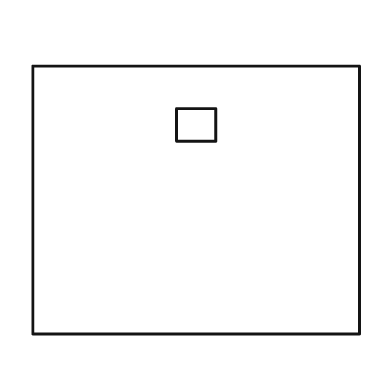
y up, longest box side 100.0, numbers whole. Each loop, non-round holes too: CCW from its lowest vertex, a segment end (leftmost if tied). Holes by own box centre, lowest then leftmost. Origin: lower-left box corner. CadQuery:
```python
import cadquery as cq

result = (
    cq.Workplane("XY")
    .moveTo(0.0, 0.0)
    .lineTo(100.0, 0.0)
    .lineTo(100.0, 82.0)
    .lineTo(0.0, 82.0)
    .close()
    .moveTo(44.0, 59.0)
    .lineTo(56.0, 59.0)
    .lineTo(56.0, 69.0)
    .lineTo(44.0, 69.0)
    .close()
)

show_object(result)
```